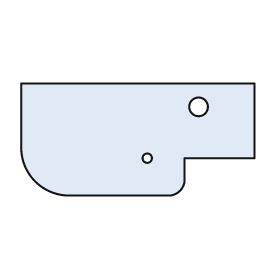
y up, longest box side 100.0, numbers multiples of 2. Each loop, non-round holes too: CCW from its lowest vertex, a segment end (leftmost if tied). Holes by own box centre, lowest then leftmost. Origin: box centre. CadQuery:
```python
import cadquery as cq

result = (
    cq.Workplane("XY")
    .moveTo(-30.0, -24.0)
    .lineTo(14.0, -24.0)
    .threePointArc((18.0, -22.0), (20.0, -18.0))
    .lineTo(20.0, -8.0)
    .lineTo(50.0, -8.0)
    .lineTo(50.0, 24.0)
    .lineTo(-50.0, 24.0)
    .lineTo(-50.0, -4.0)
    .threePointArc((-44.0, -18.0), (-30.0, -24.0))
    .close()
    .moveTo(4.0, -8.0)
    .circle(2.0)
    .moveTo(26.0, 14.0)
    .circle(4.0)
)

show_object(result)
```